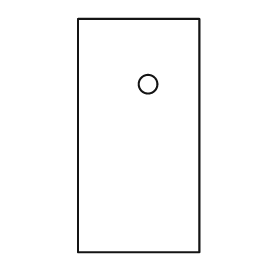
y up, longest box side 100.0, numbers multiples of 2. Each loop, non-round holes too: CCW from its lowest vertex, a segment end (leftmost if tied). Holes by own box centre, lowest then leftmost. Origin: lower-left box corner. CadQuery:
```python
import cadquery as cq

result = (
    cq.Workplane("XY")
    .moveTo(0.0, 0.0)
    .lineTo(52.0, 0.0)
    .lineTo(52.0, 100.0)
    .lineTo(0.0, 100.0)
    .close()
    .moveTo(30.0, 72.0)
    .circle(4.0)
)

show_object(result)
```